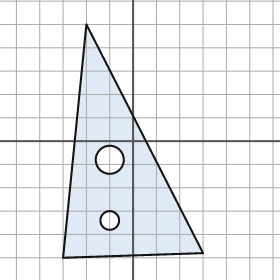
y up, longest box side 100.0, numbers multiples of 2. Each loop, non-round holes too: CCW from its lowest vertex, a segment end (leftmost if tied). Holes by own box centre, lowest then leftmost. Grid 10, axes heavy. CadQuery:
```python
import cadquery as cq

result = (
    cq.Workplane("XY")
    .moveTo(-30.0, -50.0)
    .lineTo(30.0, -48.0)
    .lineTo(-20.0, 50.0)
    .close()
    .moveTo(-10.0, -34.0)
    .circle(4.0)
    .moveTo(-10.0, -8.0)
    .circle(6.0)
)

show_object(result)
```